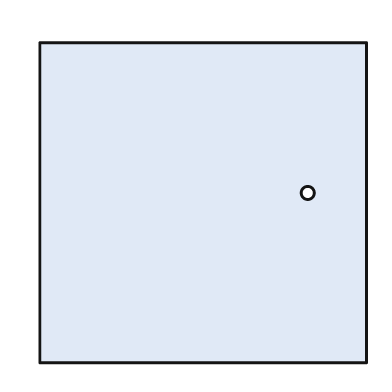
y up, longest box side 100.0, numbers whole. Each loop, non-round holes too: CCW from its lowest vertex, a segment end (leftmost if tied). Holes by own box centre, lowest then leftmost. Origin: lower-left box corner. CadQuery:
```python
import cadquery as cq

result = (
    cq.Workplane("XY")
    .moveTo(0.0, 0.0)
    .lineTo(100.0, 0.0)
    .lineTo(100.0, 98.0)
    .lineTo(0.0, 98.0)
    .close()
    .moveTo(82.0, 52.0)
    .circle(2.0)
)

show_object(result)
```